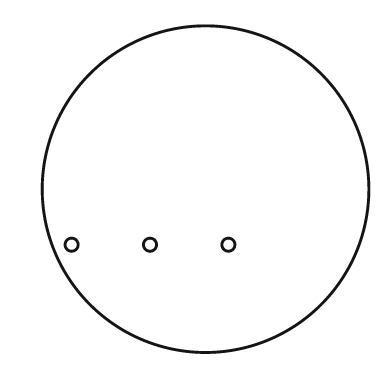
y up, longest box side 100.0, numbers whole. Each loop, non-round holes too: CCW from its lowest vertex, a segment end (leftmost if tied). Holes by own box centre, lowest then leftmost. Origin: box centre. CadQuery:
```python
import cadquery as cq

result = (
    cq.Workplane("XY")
    .moveTo(0.0, 0.0)
    .circle(50.0)
    .moveTo(-41.0, -17.0)
    .circle(2.0)
    .moveTo(-17.0, -17.0)
    .circle(2.0)
    .moveTo(7.0, -17.0)
    .circle(2.0)
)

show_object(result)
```